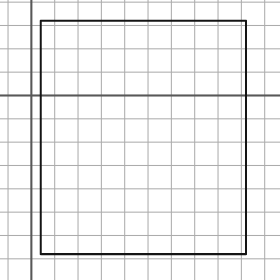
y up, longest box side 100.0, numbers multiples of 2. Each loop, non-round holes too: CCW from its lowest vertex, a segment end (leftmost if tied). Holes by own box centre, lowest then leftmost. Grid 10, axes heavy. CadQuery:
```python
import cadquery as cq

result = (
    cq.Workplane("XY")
    .moveTo(4.0, -68.0)
    .lineTo(92.0, -68.0)
    .lineTo(92.0, 32.0)
    .lineTo(4.0, 32.0)
    .close()
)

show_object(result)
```